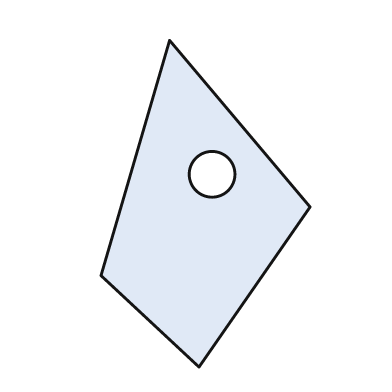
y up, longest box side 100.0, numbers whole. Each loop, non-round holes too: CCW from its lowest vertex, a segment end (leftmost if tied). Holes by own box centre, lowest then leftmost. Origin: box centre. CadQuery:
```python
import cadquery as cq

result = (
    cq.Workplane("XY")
    .moveTo(-2.0, -50.0)
    .lineTo(32.0, -1.0)
    .lineTo(-11.0, 50.0)
    .lineTo(-32.0, -22.0)
    .close()
    .moveTo(2.0, 9.0)
    .circle(7.0)
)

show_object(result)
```